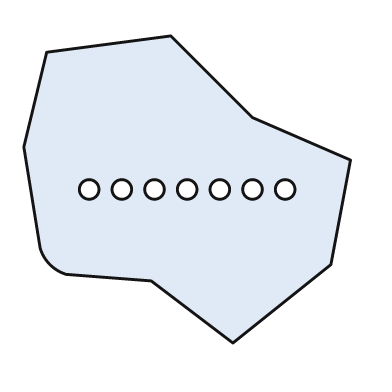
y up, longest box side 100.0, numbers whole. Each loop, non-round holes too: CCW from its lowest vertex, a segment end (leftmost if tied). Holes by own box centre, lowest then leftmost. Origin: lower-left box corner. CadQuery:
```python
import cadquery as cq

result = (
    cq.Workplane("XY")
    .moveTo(64.0, 0.0)
    .lineTo(94.0, 24.0)
    .lineTo(100.0, 56.0)
    .lineTo(70.0, 69.0)
    .lineTo(45.0, 94.0)
    .lineTo(7.0, 89.0)
    .lineTo(0.0, 60.0)
    .lineTo(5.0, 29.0)
    .threePointArc((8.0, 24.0), (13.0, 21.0))
    .lineTo(39.0, 19.0)
    .close()
    .moveTo(20.0, 47.0)
    .circle(3.0)
    .moveTo(30.0, 47.0)
    .circle(3.0)
    .moveTo(40.0, 47.0)
    .circle(3.0)
    .moveTo(50.0, 47.0)
    .circle(3.0)
    .moveTo(60.0, 47.0)
    .circle(3.0)
    .moveTo(70.0, 47.0)
    .circle(3.0)
    .moveTo(80.0, 47.0)
    .circle(3.0)
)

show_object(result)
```